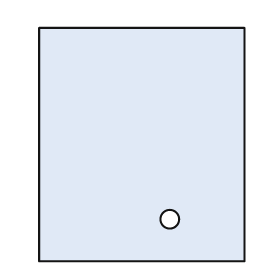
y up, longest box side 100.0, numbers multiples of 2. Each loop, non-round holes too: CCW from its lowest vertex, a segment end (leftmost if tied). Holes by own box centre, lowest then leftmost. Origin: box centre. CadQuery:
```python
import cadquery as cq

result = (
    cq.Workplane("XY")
    .moveTo(-44.0, -50.0)
    .lineTo(44.0, -50.0)
    .lineTo(44.0, 50.0)
    .lineTo(-44.0, 50.0)
    .close()
    .moveTo(12.0, -32.0)
    .circle(4.0)
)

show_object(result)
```